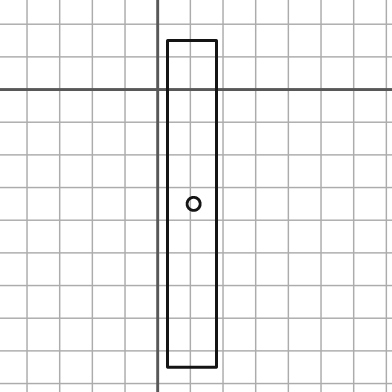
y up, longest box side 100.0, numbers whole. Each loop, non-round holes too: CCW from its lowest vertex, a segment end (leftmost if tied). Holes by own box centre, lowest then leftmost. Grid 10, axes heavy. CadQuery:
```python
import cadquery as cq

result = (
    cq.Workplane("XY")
    .moveTo(3.0, -85.0)
    .lineTo(18.0, -85.0)
    .lineTo(18.0, 15.0)
    .lineTo(3.0, 15.0)
    .close()
    .moveTo(11.0, -35.0)
    .circle(2.0)
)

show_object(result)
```